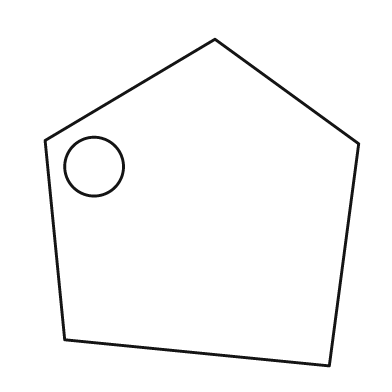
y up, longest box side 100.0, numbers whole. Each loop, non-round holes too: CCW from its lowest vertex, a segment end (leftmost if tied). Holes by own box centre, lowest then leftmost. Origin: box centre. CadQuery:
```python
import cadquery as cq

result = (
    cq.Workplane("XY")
    .moveTo(39.0, -50.0)
    .lineTo(48.0, 18.0)
    .lineTo(4.0, 50.0)
    .lineTo(-48.0, 19.0)
    .lineTo(-42.0, -42.0)
    .close()
    .moveTo(-33.0, 11.0)
    .circle(9.0)
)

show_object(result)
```